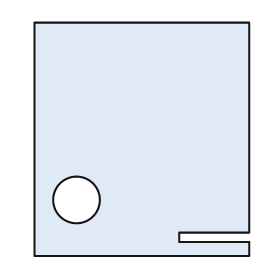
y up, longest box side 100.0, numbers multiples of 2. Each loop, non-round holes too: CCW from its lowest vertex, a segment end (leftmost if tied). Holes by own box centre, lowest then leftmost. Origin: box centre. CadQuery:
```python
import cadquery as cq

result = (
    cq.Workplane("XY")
    .moveTo(-46.0, -50.0)
    .lineTo(46.0, -50.0)
    .lineTo(46.0, -44.0)
    .lineTo(16.0, -44.0)
    .lineTo(16.0, -40.0)
    .lineTo(46.0, -40.0)
    .lineTo(46.0, 50.0)
    .lineTo(-46.0, 50.0)
    .close()
    .moveTo(-28.0, -26.0)
    .circle(10.0)
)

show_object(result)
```